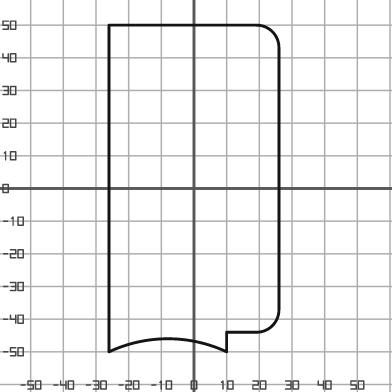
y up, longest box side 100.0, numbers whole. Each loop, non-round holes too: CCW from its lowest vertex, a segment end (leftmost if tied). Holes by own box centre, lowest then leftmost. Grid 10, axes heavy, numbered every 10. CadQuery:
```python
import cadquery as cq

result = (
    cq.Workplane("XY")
    .moveTo(-26.0, -50.0)
    .threePointArc((-8.0, -46.0), (10.0, -50.0))
    .lineTo(10.0, -44.0)
    .lineTo(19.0, -44.0)
    .threePointArc((24.0, -42.0), (26.0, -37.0))
    .lineTo(26.0, 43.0)
    .threePointArc((24.0, 48.0), (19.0, 50.0))
    .lineTo(-26.0, 50.0)
    .close()
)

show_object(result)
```